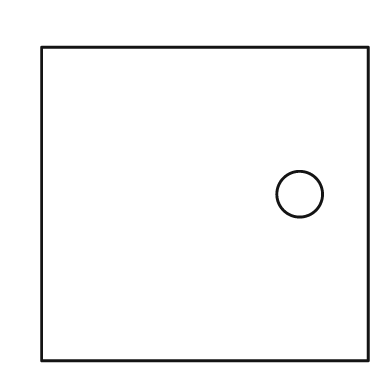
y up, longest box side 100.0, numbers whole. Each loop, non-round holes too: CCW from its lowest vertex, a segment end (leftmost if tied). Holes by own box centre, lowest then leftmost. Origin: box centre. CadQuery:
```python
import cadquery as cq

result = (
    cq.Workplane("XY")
    .moveTo(-50.0, -48.0)
    .lineTo(50.0, -48.0)
    .lineTo(50.0, 48.0)
    .lineTo(-50.0, 48.0)
    .close()
    .moveTo(29.0, 3.0)
    .circle(7.0)
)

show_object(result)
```